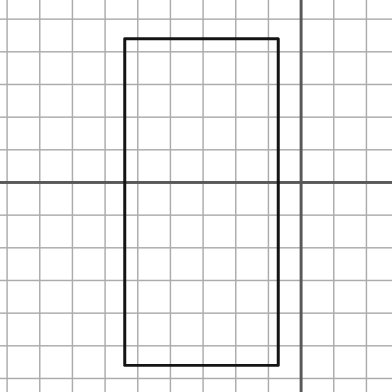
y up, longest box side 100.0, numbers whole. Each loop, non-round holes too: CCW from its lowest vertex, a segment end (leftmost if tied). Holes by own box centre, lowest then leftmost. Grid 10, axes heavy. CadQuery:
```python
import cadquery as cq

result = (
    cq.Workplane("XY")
    .moveTo(-54.0, -56.0)
    .lineTo(-7.0, -56.0)
    .lineTo(-7.0, 44.0)
    .lineTo(-54.0, 44.0)
    .close()
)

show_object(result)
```